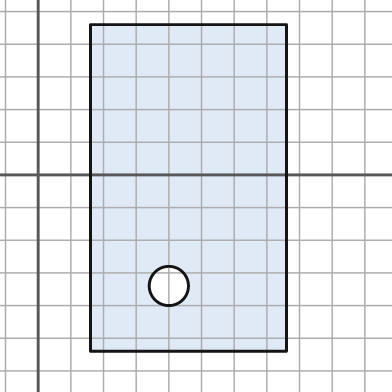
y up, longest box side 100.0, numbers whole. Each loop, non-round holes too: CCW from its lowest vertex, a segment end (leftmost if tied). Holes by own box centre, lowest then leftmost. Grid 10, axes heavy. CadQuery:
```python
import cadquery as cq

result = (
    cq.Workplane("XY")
    .moveTo(16.0, -54.0)
    .lineTo(76.0, -54.0)
    .lineTo(76.0, 46.0)
    .lineTo(16.0, 46.0)
    .close()
    .moveTo(40.0, -34.0)
    .circle(6.0)
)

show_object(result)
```